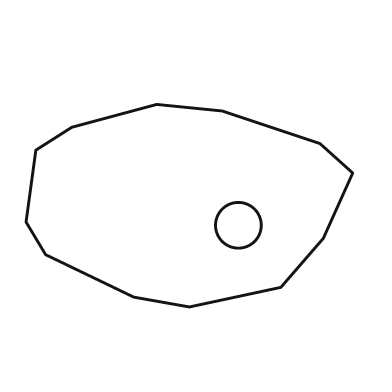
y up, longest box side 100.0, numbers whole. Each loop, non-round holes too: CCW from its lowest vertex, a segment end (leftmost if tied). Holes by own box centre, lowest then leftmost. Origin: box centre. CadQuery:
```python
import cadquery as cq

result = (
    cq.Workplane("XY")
    .moveTo(0.0, -31.0)
    .lineTo(28.0, -25.0)
    .lineTo(41.0, -10.0)
    .lineTo(50.0, 10.0)
    .lineTo(40.0, 19.0)
    .lineTo(10.0, 29.0)
    .lineTo(-10.0, 31.0)
    .lineTo(-36.0, 24.0)
    .lineTo(-47.0, 17.0)
    .lineTo(-50.0, -5.0)
    .lineTo(-44.0, -15.0)
    .lineTo(-17.0, -28.0)
    .close()
    .moveTo(15.0, -6.0)
    .circle(7.0)
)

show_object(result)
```